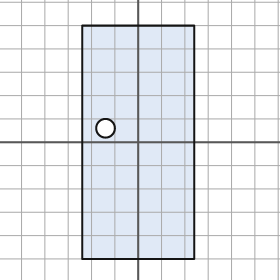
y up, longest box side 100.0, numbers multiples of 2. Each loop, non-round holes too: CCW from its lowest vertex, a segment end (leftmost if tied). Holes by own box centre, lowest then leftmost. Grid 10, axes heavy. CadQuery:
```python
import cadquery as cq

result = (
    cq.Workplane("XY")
    .moveTo(-24.0, -50.0)
    .lineTo(24.0, -50.0)
    .lineTo(24.0, 50.0)
    .lineTo(-24.0, 50.0)
    .close()
    .moveTo(-14.0, 6.0)
    .circle(4.0)
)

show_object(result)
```